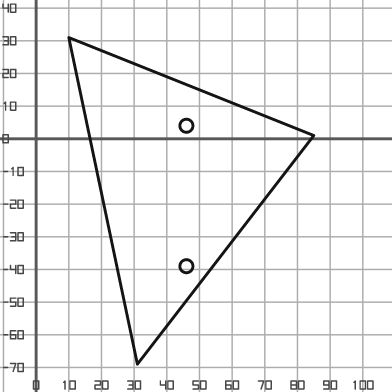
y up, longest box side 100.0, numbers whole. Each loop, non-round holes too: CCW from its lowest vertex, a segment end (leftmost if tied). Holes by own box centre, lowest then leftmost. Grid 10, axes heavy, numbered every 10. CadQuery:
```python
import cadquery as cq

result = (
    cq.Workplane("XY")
    .moveTo(31.0, -69.0)
    .lineTo(85.0, 1.0)
    .lineTo(10.0, 31.0)
    .close()
    .moveTo(46.0, -39.0)
    .circle(2.0)
    .moveTo(46.0, 4.0)
    .circle(2.0)
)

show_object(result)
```